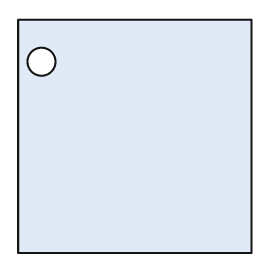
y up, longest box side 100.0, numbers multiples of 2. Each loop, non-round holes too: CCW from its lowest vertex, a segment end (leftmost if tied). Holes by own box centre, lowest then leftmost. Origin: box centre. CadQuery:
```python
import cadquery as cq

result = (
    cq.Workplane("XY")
    .moveTo(-50.0, -50.0)
    .lineTo(50.0, -50.0)
    .lineTo(50.0, 50.0)
    .lineTo(-50.0, 50.0)
    .close()
    .moveTo(-40.0, 32.0)
    .circle(6.0)
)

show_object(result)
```